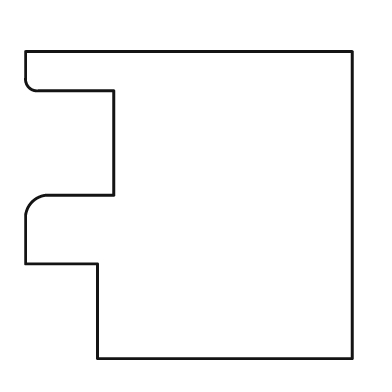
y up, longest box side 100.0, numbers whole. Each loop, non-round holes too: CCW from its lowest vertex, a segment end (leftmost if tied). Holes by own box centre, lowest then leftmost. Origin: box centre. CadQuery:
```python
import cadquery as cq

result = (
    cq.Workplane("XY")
    .moveTo(-28.0, -47.0)
    .lineTo(50.0, -47.0)
    .lineTo(50.0, 47.0)
    .lineTo(-50.0, 47.0)
    .lineTo(-50.0, 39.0)
    .threePointArc((-49.0, 36.0), (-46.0, 35.0))
    .lineTo(-23.0, 35.0)
    .lineTo(-23.0, 3.0)
    .lineTo(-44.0, 3.0)
    .threePointArc((-48.0, 1.0), (-50.0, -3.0))
    .lineTo(-50.0, -18.0)
    .lineTo(-28.0, -18.0)
    .close()
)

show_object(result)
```